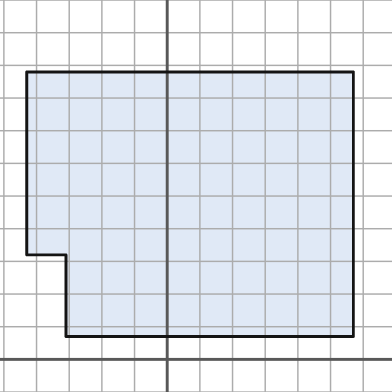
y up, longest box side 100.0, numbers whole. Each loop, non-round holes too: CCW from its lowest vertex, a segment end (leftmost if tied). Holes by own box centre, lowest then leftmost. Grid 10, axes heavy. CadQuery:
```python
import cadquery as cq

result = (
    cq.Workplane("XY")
    .moveTo(-31.0, 7.0)
    .lineTo(57.0, 7.0)
    .lineTo(57.0, 88.0)
    .lineTo(-43.0, 88.0)
    .lineTo(-43.0, 32.0)
    .lineTo(-31.0, 32.0)
    .close()
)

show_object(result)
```